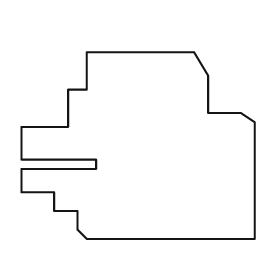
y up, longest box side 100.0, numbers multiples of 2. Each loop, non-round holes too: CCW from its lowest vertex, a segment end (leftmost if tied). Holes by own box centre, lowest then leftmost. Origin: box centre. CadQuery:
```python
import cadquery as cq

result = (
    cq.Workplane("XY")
    .moveTo(-22.0, -40.0)
    .lineTo(50.0, -40.0)
    .lineTo(50.0, 10.0)
    .lineTo(44.0, 14.0)
    .lineTo(30.0, 14.0)
    .lineTo(30.0, 30.0)
    .lineTo(24.0, 40.0)
    .lineTo(-22.0, 40.0)
    .lineTo(-22.0, 24.0)
    .lineTo(-30.0, 24.0)
    .lineTo(-30.0, 8.0)
    .lineTo(-50.0, 8.0)
    .lineTo(-50.0, -6.0)
    .lineTo(-18.0, -6.0)
    .lineTo(-18.0, -10.0)
    .lineTo(-50.0, -10.0)
    .lineTo(-50.0, -20.0)
    .lineTo(-36.0, -20.0)
    .lineTo(-36.0, -28.0)
    .lineTo(-26.0, -28.0)
    .lineTo(-26.0, -36.0)
    .close()
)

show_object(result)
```